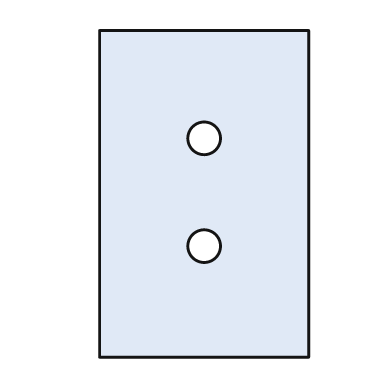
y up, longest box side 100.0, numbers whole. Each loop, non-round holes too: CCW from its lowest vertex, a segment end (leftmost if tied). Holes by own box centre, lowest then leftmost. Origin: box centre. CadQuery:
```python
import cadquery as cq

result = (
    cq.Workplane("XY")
    .moveTo(-32.0, -50.0)
    .lineTo(32.0, -50.0)
    .lineTo(32.0, 50.0)
    .lineTo(-32.0, 50.0)
    .close()
    .moveTo(0.0, -16.0)
    .circle(5.0)
    .moveTo(0.0, 17.0)
    .circle(5.0)
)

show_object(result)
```